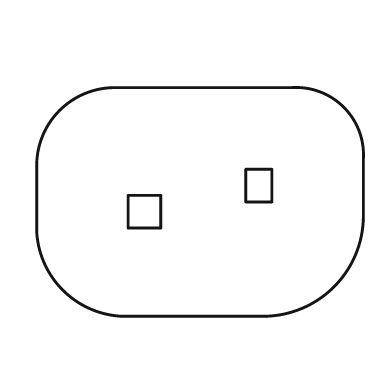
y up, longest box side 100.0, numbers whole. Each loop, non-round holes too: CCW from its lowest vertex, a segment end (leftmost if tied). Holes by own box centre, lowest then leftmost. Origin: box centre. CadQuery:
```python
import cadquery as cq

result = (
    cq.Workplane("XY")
    .moveTo(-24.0, -35.0)
    .lineTo(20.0, -35.0)
    .threePointArc((41.0, -26.0), (50.0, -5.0))
    .lineTo(50.0, 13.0)
    .threePointArc((44.0, 29.0), (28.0, 35.0))
    .lineTo(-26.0, 35.0)
    .threePointArc((-43.0, 28.0), (-50.0, 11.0))
    .lineTo(-50.0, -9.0)
    .threePointArc((-42.0, -27.0), (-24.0, -35.0))
    .close()
    .moveTo(-22.0, -8.0)
    .lineTo(-12.0, -8.0)
    .lineTo(-12.0, 2.0)
    .lineTo(-22.0, 2.0)
    .close()
    .moveTo(14.0, 0.0)
    .lineTo(22.0, 0.0)
    .lineTo(22.0, 10.0)
    .lineTo(14.0, 10.0)
    .close()
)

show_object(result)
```